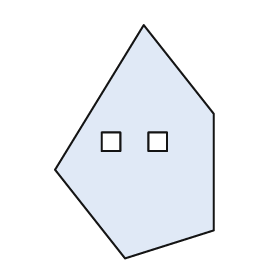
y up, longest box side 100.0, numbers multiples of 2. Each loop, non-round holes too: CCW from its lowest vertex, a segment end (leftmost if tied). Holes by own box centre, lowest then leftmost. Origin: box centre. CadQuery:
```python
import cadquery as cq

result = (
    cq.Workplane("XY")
    .moveTo(-4.0, -50.0)
    .lineTo(34.0, -38.0)
    .lineTo(34.0, 12.0)
    .lineTo(4.0, 50.0)
    .lineTo(-34.0, -12.0)
    .close()
    .moveTo(-14.0, -4.0)
    .lineTo(-6.0, -4.0)
    .lineTo(-6.0, 4.0)
    .lineTo(-14.0, 4.0)
    .close()
    .moveTo(6.0, -4.0)
    .lineTo(14.0, -4.0)
    .lineTo(14.0, 4.0)
    .lineTo(6.0, 4.0)
    .close()
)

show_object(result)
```